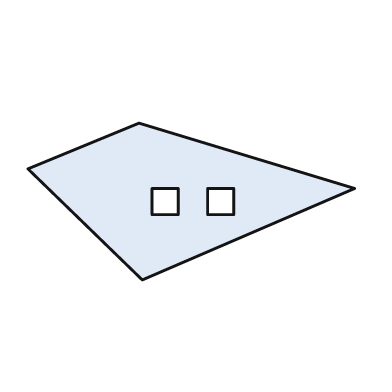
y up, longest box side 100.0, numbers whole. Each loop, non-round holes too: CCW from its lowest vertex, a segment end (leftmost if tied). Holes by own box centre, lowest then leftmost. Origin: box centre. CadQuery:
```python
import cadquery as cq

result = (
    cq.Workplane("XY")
    .moveTo(-15.0, -24.0)
    .lineTo(50.0, 4.0)
    .lineTo(-16.0, 24.0)
    .lineTo(-50.0, 10.0)
    .close()
    .moveTo(-12.0, -4.0)
    .lineTo(-4.0, -4.0)
    .lineTo(-4.0, 4.0)
    .lineTo(-12.0, 4.0)
    .close()
    .moveTo(5.0, -4.0)
    .lineTo(13.0, -4.0)
    .lineTo(13.0, 4.0)
    .lineTo(5.0, 4.0)
    .close()
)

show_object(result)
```